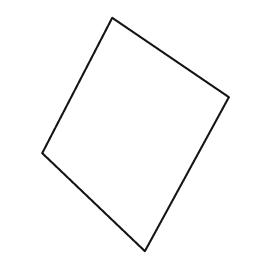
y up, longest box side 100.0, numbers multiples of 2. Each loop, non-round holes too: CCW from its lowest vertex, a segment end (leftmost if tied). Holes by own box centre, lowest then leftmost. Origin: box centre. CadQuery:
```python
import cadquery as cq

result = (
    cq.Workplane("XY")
    .moveTo(4.0, -50.0)
    .lineTo(40.0, 16.0)
    .lineTo(-10.0, 50.0)
    .lineTo(-40.0, -8.0)
    .close()
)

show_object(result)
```